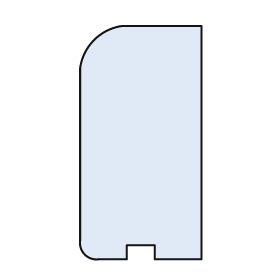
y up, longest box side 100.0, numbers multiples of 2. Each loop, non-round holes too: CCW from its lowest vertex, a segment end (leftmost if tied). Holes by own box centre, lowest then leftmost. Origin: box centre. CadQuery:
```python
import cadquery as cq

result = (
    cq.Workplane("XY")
    .moveTo(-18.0, -50.0)
    .lineTo(-6.0, -50.0)
    .lineTo(-6.0, -44.0)
    .lineTo(6.0, -44.0)
    .lineTo(6.0, -50.0)
    .lineTo(26.0, -50.0)
    .lineTo(26.0, 50.0)
    .lineTo(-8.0, 50.0)
    .threePointArc((-20.0, 44.0), (-26.0, 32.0))
    .lineTo(-26.0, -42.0)
    .threePointArc((-24.0, -48.0), (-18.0, -50.0))
    .close()
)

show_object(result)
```